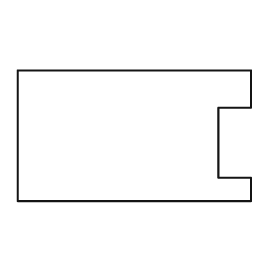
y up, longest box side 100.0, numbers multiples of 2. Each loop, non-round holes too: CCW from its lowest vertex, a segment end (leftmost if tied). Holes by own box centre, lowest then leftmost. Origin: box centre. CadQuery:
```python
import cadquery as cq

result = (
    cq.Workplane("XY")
    .moveTo(-50.0, -28.0)
    .lineTo(50.0, -28.0)
    .lineTo(50.0, -18.0)
    .lineTo(36.0, -18.0)
    .lineTo(36.0, 12.0)
    .lineTo(50.0, 12.0)
    .lineTo(50.0, 28.0)
    .lineTo(-50.0, 28.0)
    .close()
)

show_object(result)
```